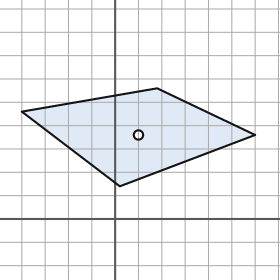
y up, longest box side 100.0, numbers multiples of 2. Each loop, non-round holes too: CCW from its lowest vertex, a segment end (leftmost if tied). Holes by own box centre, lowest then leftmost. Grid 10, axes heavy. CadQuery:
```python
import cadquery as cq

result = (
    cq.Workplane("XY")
    .moveTo(2.0, 14.0)
    .lineTo(60.0, 36.0)
    .lineTo(18.0, 56.0)
    .lineTo(-40.0, 46.0)
    .close()
    .moveTo(10.0, 36.0)
    .circle(2.0)
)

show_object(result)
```